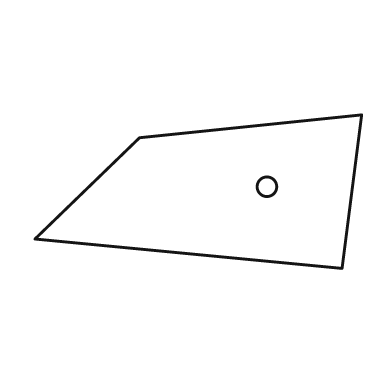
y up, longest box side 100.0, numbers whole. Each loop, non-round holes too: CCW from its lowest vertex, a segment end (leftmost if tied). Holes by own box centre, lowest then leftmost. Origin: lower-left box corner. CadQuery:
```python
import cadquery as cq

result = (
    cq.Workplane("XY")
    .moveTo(94.0, 0.0)
    .lineTo(100.0, 47.0)
    .lineTo(32.0, 40.0)
    .lineTo(0.0, 9.0)
    .close()
    .moveTo(71.0, 25.0)
    .circle(3.0)
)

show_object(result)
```